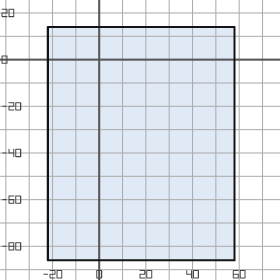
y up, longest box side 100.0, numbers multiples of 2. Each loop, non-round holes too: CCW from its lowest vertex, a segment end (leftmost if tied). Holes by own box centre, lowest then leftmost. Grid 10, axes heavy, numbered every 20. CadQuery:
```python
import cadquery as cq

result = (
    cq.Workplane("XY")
    .moveTo(-22.0, -86.0)
    .lineTo(58.0, -86.0)
    .lineTo(58.0, 14.0)
    .lineTo(-22.0, 14.0)
    .close()
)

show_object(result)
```